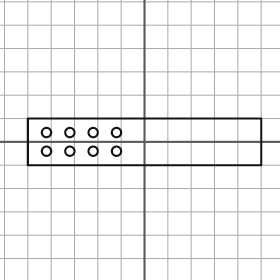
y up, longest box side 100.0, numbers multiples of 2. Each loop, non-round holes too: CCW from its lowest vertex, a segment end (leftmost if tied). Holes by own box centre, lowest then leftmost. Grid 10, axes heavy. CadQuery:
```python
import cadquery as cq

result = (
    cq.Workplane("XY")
    .moveTo(-50.0, -10.0)
    .lineTo(50.0, -10.0)
    .lineTo(50.0, 10.0)
    .lineTo(-50.0, 10.0)
    .close()
    .moveTo(-42.0, -4.0)
    .circle(2.0)
    .moveTo(-32.0, -4.0)
    .circle(2.0)
    .moveTo(-22.0, -4.0)
    .circle(2.0)
    .moveTo(-12.0, -4.0)
    .circle(2.0)
    .moveTo(-42.0, 4.0)
    .circle(2.0)
    .moveTo(-32.0, 4.0)
    .circle(2.0)
    .moveTo(-22.0, 4.0)
    .circle(2.0)
    .moveTo(-12.0, 4.0)
    .circle(2.0)
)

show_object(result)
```